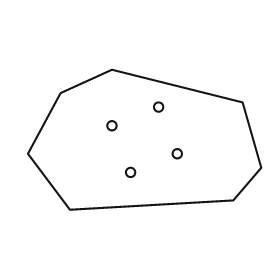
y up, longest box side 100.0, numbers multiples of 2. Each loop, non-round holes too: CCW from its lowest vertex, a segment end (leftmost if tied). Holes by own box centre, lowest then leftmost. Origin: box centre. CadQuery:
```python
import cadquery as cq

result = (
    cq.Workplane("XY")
    .moveTo(-32.0, -30.0)
    .lineTo(38.0, -26.0)
    .lineTo(50.0, -12.0)
    .lineTo(42.0, 16.0)
    .lineTo(-14.0, 30.0)
    .lineTo(-36.0, 20.0)
    .lineTo(-50.0, -6.0)
    .close()
    .moveTo(-6.0, -14.0)
    .circle(2.0)
    .moveTo(14.0, -6.0)
    .circle(2.0)
    .moveTo(-14.0, 6.0)
    .circle(2.0)
    .moveTo(6.0, 14.0)
    .circle(2.0)
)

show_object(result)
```